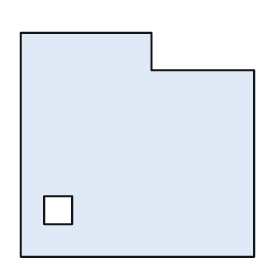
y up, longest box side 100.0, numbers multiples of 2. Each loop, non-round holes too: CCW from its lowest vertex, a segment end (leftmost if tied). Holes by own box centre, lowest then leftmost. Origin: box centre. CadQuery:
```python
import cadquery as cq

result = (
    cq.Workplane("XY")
    .moveTo(-50.0, -48.0)
    .lineTo(50.0, -48.0)
    .lineTo(50.0, 32.0)
    .lineTo(6.0, 32.0)
    .lineTo(6.0, 48.0)
    .lineTo(-50.0, 48.0)
    .close()
    .moveTo(-40.0, -34.0)
    .lineTo(-28.0, -34.0)
    .lineTo(-28.0, -22.0)
    .lineTo(-40.0, -22.0)
    .close()
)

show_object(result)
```